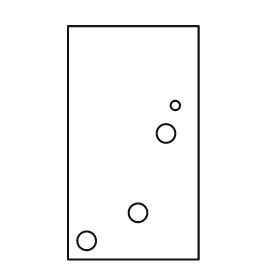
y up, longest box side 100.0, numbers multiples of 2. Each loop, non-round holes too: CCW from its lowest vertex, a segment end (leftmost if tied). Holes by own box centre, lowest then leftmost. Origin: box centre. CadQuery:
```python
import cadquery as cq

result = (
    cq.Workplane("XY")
    .moveTo(-28.0, -50.0)
    .lineTo(28.0, -50.0)
    .lineTo(28.0, 50.0)
    .lineTo(-28.0, 50.0)
    .close()
    .moveTo(-20.0, -42.0)
    .circle(4.0)
    .moveTo(2.0, -30.0)
    .circle(4.0)
    .moveTo(14.0, 4.0)
    .circle(4.0)
    .moveTo(18.0, 16.0)
    .circle(2.0)
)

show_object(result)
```